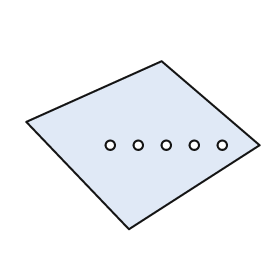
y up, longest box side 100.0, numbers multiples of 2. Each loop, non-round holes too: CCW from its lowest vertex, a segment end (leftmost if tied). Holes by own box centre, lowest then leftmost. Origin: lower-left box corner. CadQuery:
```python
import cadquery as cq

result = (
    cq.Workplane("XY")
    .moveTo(44.0, 0.0)
    .lineTo(100.0, 36.0)
    .lineTo(58.0, 72.0)
    .lineTo(0.0, 46.0)
    .close()
    .moveTo(36.0, 36.0)
    .circle(2.0)
    .moveTo(48.0, 36.0)
    .circle(2.0)
    .moveTo(60.0, 36.0)
    .circle(2.0)
    .moveTo(72.0, 36.0)
    .circle(2.0)
    .moveTo(84.0, 36.0)
    .circle(2.0)
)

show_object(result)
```